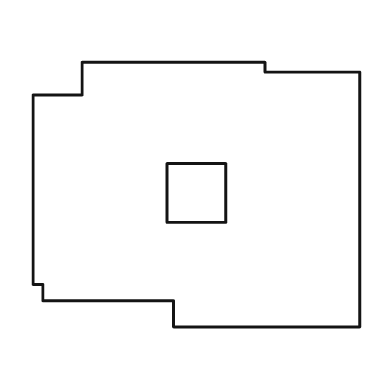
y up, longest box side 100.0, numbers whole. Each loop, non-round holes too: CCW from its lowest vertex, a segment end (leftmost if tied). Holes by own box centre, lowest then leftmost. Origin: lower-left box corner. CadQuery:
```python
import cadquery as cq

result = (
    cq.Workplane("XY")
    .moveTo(43.0, 0.0)
    .lineTo(100.0, 0.0)
    .lineTo(100.0, 78.0)
    .lineTo(71.0, 78.0)
    .lineTo(71.0, 81.0)
    .lineTo(15.0, 81.0)
    .lineTo(15.0, 71.0)
    .lineTo(0.0, 71.0)
    .lineTo(0.0, 13.0)
    .lineTo(3.0, 13.0)
    .lineTo(3.0, 8.0)
    .lineTo(43.0, 8.0)
    .close()
    .moveTo(41.0, 32.0)
    .lineTo(59.0, 32.0)
    .lineTo(59.0, 50.0)
    .lineTo(41.0, 50.0)
    .close()
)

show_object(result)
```